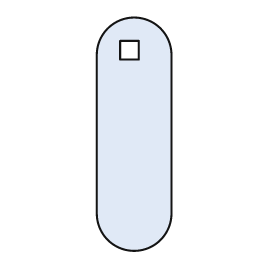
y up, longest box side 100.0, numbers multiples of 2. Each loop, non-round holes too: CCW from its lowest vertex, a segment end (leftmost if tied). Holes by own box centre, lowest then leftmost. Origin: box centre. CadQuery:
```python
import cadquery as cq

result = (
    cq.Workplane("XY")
    .moveTo(-16.0, -34.0)
    .threePointArc((0.0, -50.0), (16.0, -34.0))
    .lineTo(16.0, 34.0)
    .threePointArc((0.0, 50.0), (-16.0, 34.0))
    .close()
    .moveTo(-6.0, 32.0)
    .lineTo(2.0, 32.0)
    .lineTo(2.0, 40.0)
    .lineTo(-6.0, 40.0)
    .close()
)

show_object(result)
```